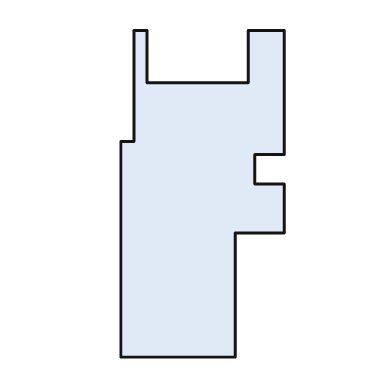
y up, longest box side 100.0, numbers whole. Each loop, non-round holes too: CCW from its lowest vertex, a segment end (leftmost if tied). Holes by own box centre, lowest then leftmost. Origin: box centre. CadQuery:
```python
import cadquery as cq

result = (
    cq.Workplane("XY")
    .moveTo(-25.0, -50.0)
    .lineTo(10.0, -50.0)
    .lineTo(10.0, -12.0)
    .lineTo(25.0, -12.0)
    .lineTo(25.0, 3.0)
    .lineTo(16.0, 3.0)
    .lineTo(16.0, 12.0)
    .lineTo(25.0, 12.0)
    .lineTo(25.0, 50.0)
    .lineTo(14.0, 50.0)
    .lineTo(14.0, 34.0)
    .lineTo(-17.0, 34.0)
    .lineTo(-17.0, 50.0)
    .lineTo(-21.0, 50.0)
    .lineTo(-21.0, 16.0)
    .lineTo(-25.0, 16.0)
    .close()
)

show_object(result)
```